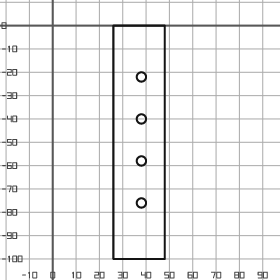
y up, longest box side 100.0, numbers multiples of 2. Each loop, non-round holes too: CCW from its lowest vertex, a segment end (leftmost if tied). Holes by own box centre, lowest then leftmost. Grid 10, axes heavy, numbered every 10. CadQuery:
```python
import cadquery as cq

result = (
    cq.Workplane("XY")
    .moveTo(26.0, -100.0)
    .lineTo(48.0, -100.0)
    .lineTo(48.0, 0.0)
    .lineTo(26.0, 0.0)
    .close()
    .moveTo(38.0, -76.0)
    .circle(2.0)
    .moveTo(38.0, -58.0)
    .circle(2.0)
    .moveTo(38.0, -40.0)
    .circle(2.0)
    .moveTo(38.0, -22.0)
    .circle(2.0)
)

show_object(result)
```